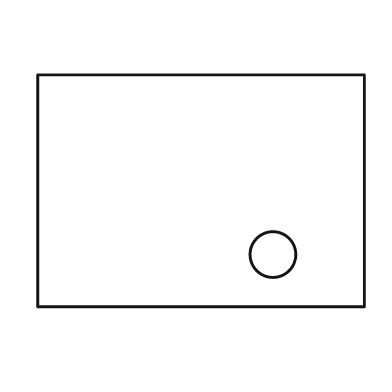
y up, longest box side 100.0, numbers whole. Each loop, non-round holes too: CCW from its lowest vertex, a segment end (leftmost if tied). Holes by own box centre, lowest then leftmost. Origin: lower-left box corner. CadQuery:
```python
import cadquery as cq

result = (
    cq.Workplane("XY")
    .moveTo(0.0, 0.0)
    .lineTo(100.0, 0.0)
    .lineTo(100.0, 71.0)
    .lineTo(0.0, 71.0)
    .close()
    .moveTo(72.0, 16.0)
    .circle(7.0)
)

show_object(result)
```